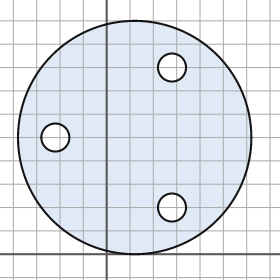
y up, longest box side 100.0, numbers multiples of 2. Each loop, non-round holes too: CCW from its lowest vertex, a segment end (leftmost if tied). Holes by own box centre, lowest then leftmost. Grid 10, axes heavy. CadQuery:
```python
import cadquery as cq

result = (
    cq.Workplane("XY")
    .moveTo(12.0, 50.0)
    .circle(50.0)
    .moveTo(28.0, 20.0)
    .circle(6.0)
    .moveTo(-22.0, 50.0)
    .circle(6.0)
    .moveTo(28.0, 80.0)
    .circle(6.0)
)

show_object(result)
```